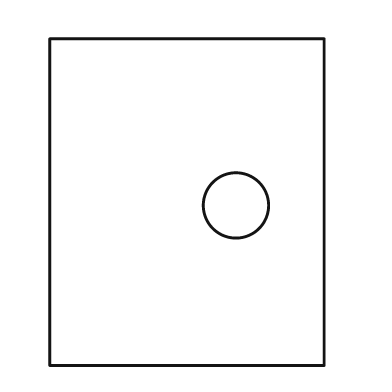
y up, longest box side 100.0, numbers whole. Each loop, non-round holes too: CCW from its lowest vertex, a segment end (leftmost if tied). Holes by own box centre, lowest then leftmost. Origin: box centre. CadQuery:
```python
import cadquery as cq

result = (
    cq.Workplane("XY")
    .moveTo(-42.0, -50.0)
    .lineTo(42.0, -50.0)
    .lineTo(42.0, 50.0)
    .lineTo(-42.0, 50.0)
    .close()
    .moveTo(15.0, -1.0)
    .circle(10.0)
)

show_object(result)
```